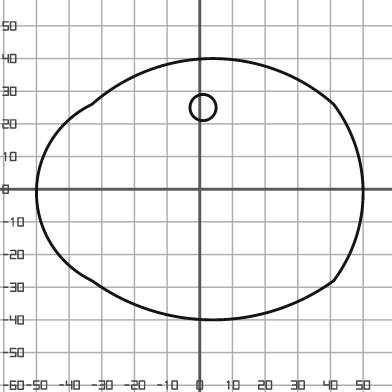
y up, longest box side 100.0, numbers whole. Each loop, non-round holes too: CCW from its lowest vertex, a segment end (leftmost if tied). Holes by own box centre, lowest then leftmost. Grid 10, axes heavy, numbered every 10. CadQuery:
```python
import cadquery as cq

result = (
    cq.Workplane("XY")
    .moveTo(-33.0, -28.0)
    .threePointArc((4.0, -40.0), (41.0, -28.0))
    .threePointArc((50.0, -1.0), (41.0, 26.0))
    .threePointArc((4.0, 40.0), (-33.0, 26.0))
    .threePointArc((-50.0, -1.0), (-33.0, -28.0))
    .close()
    .moveTo(1.0, 25.0)
    .circle(4.0)
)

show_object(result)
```